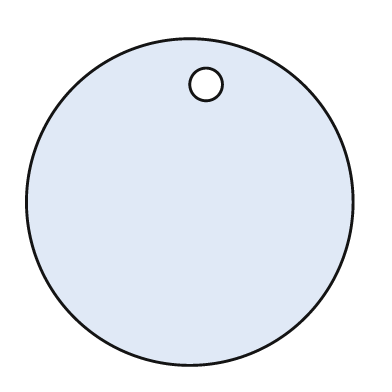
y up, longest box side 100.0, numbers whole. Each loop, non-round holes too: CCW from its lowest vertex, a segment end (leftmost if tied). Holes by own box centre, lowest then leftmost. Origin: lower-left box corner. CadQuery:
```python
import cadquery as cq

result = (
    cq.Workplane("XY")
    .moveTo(50.0, 50.0)
    .circle(50.0)
    .moveTo(55.0, 86.0)
    .circle(5.0)
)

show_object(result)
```